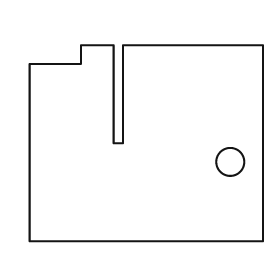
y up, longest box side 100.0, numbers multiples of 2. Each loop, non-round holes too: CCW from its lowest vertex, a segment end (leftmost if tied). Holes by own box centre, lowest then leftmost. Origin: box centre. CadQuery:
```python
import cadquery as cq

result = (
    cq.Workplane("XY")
    .moveTo(-50.0, -42.0)
    .lineTo(50.0, -42.0)
    .lineTo(50.0, 42.0)
    .lineTo(-10.0, 42.0)
    .lineTo(-10.0, 0.0)
    .lineTo(-14.0, 0.0)
    .lineTo(-14.0, 42.0)
    .lineTo(-28.0, 42.0)
    .lineTo(-28.0, 34.0)
    .lineTo(-50.0, 34.0)
    .close()
    .moveTo(36.0, -8.0)
    .circle(6.0)
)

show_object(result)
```